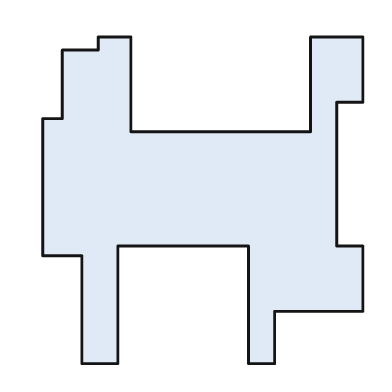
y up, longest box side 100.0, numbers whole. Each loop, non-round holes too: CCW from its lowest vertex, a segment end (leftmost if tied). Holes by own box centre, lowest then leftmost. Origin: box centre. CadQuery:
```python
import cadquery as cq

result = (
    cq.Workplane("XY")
    .moveTo(-37.0, -50.0)
    .lineTo(-26.0, -50.0)
    .lineTo(-26.0, -14.0)
    .lineTo(14.0, -14.0)
    .lineTo(14.0, -50.0)
    .lineTo(22.0, -50.0)
    .lineTo(22.0, -34.0)
    .lineTo(49.0, -34.0)
    .lineTo(49.0, -14.0)
    .lineTo(41.0, -14.0)
    .lineTo(41.0, 30.0)
    .lineTo(49.0, 30.0)
    .lineTo(49.0, 50.0)
    .lineTo(33.0, 50.0)
    .lineTo(33.0, 21.0)
    .lineTo(-22.0, 21.0)
    .lineTo(-22.0, 50.0)
    .lineTo(-32.0, 50.0)
    .lineTo(-32.0, 46.0)
    .lineTo(-43.0, 46.0)
    .lineTo(-43.0, 25.0)
    .lineTo(-49.0, 25.0)
    .lineTo(-49.0, -17.0)
    .lineTo(-37.0, -17.0)
    .close()
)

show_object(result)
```